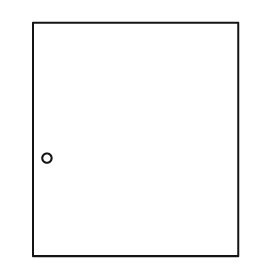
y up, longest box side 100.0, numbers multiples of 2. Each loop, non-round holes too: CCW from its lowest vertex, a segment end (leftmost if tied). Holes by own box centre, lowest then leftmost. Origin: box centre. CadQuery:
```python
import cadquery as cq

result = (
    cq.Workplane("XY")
    .moveTo(-44.0, -50.0)
    .lineTo(44.0, -50.0)
    .lineTo(44.0, 50.0)
    .lineTo(-44.0, 50.0)
    .close()
    .moveTo(-38.0, -8.0)
    .circle(2.0)
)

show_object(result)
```